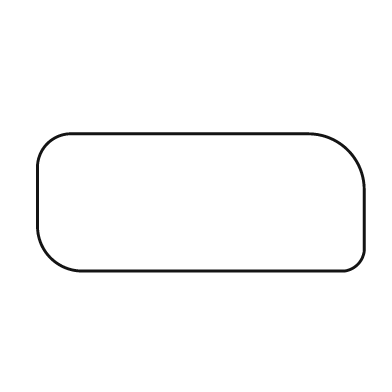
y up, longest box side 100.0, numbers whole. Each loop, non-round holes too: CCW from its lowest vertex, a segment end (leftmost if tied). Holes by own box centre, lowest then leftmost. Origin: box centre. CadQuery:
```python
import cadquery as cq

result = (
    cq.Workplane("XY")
    .moveTo(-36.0, -21.0)
    .lineTo(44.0, -21.0)
    .threePointArc((48.0, -19.0), (50.0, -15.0))
    .lineTo(50.0, 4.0)
    .threePointArc((45.0, 16.0), (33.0, 21.0))
    .lineTo(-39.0, 21.0)
    .threePointArc((-47.0, 18.0), (-50.0, 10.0))
    .lineTo(-50.0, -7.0)
    .threePointArc((-46.0, -17.0), (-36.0, -21.0))
    .close()
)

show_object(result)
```